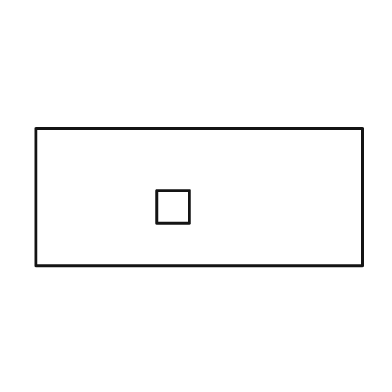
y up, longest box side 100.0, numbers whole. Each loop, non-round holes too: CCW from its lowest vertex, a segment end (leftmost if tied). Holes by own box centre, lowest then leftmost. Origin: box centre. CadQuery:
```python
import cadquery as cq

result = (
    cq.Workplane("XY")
    .moveTo(-50.0, -21.0)
    .lineTo(50.0, -21.0)
    .lineTo(50.0, 21.0)
    .lineTo(-50.0, 21.0)
    .close()
    .moveTo(-13.0, -8.0)
    .lineTo(-3.0, -8.0)
    .lineTo(-3.0, 2.0)
    .lineTo(-13.0, 2.0)
    .close()
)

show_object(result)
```